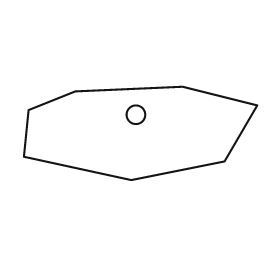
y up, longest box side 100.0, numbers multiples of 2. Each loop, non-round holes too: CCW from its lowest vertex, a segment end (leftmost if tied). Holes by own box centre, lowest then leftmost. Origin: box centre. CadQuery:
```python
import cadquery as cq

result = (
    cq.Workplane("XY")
    .moveTo(-4.0, -20.0)
    .lineTo(36.0, -12.0)
    .lineTo(50.0, 12.0)
    .lineTo(18.0, 20.0)
    .lineTo(-28.0, 18.0)
    .lineTo(-48.0, 10.0)
    .lineTo(-50.0, -10.0)
    .close()
    .moveTo(-2.0, 8.0)
    .circle(4.0)
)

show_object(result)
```